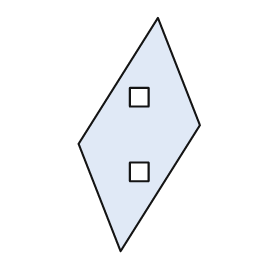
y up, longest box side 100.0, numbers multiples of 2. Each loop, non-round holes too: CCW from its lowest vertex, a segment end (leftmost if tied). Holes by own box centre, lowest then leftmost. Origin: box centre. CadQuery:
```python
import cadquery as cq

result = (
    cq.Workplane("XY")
    .moveTo(-8.0, -50.0)
    .lineTo(26.0, 4.0)
    .lineTo(8.0, 50.0)
    .lineTo(-26.0, -4.0)
    .close()
    .moveTo(-4.0, -20.0)
    .lineTo(4.0, -20.0)
    .lineTo(4.0, -12.0)
    .lineTo(-4.0, -12.0)
    .close()
    .moveTo(-4.0, 12.0)
    .lineTo(4.0, 12.0)
    .lineTo(4.0, 20.0)
    .lineTo(-4.0, 20.0)
    .close()
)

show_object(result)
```